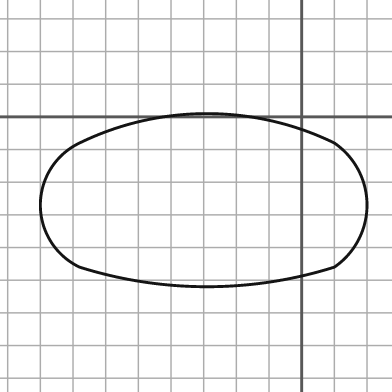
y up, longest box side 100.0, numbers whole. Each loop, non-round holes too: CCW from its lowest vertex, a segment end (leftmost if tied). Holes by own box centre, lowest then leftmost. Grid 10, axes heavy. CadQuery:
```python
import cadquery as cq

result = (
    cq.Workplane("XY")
    .moveTo(-68.0, -46.0)
    .threePointArc((-29.0, -52.0), (10.0, -46.0))
    .threePointArc((20.0, -27.0), (10.0, -8.0))
    .threePointArc((-29.0, 1.0), (-68.0, -8.0))
    .threePointArc((-80.0, -27.0), (-68.0, -46.0))
    .close()
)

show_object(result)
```